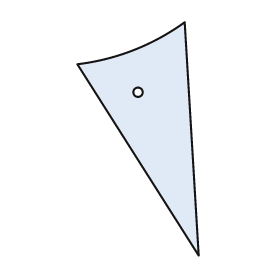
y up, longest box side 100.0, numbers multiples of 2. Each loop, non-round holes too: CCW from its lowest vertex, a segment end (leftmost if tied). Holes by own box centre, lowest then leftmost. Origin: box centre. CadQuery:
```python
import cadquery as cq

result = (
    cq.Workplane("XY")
    .moveTo(26.0, -50.0)
    .lineTo(20.0, 50.0)
    .threePointArc((-2.0, 38.0), (-26.0, 32.0))
    .close()
    .moveTo(0.0, 20.0)
    .circle(2.0)
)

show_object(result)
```